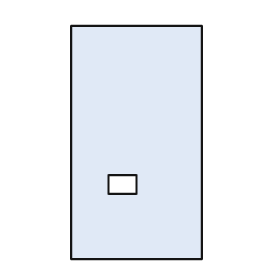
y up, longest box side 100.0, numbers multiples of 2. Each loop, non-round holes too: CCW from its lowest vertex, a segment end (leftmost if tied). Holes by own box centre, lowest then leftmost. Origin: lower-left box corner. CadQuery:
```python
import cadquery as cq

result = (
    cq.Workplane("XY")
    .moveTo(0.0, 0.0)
    .lineTo(56.0, 0.0)
    .lineTo(56.0, 100.0)
    .lineTo(0.0, 100.0)
    .close()
    .moveTo(16.0, 28.0)
    .lineTo(28.0, 28.0)
    .lineTo(28.0, 36.0)
    .lineTo(16.0, 36.0)
    .close()
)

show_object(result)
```